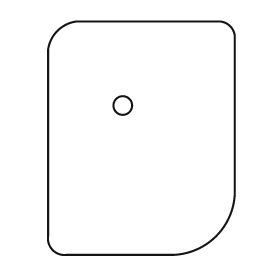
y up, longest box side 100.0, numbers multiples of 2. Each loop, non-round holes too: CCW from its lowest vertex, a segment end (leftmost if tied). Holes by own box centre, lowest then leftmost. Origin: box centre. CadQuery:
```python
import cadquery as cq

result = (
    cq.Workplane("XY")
    .moveTo(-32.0, -50.0)
    .lineTo(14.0, -50.0)
    .threePointArc((32.0, -42.0), (40.0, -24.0))
    .lineTo(40.0, 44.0)
    .threePointArc((38.0, 48.0), (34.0, 50.0))
    .lineTo(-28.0, 50.0)
    .threePointArc((-36.0, 46.0), (-40.0, 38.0))
    .lineTo(-40.0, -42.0)
    .threePointArc((-38.0, -48.0), (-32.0, -50.0))
    .close()
    .moveTo(-8.0, 14.0)
    .circle(4.0)
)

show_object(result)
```